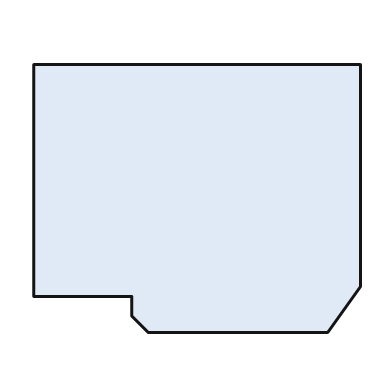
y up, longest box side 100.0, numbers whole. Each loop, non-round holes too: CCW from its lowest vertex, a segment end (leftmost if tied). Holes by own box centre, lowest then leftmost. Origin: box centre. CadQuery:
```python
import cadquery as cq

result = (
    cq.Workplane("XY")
    .moveTo(-15.0, -41.0)
    .lineTo(40.0, -41.0)
    .lineTo(50.0, -27.0)
    .lineTo(50.0, 41.0)
    .lineTo(-50.0, 41.0)
    .lineTo(-50.0, -30.0)
    .lineTo(-20.0, -30.0)
    .lineTo(-20.0, -36.0)
    .close()
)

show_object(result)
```